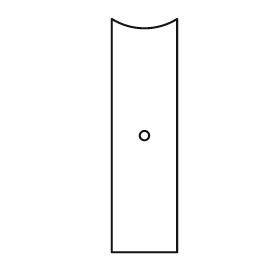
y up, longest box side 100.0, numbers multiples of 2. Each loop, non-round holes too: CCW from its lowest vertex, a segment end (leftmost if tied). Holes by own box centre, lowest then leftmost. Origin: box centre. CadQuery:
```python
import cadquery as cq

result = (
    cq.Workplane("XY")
    .moveTo(-14.0, -50.0)
    .lineTo(14.0, -50.0)
    .lineTo(14.0, 50.0)
    .threePointArc((0.0, 46.0), (-14.0, 50.0))
    .close()
    .moveTo(0.0, 0.0)
    .circle(2.0)
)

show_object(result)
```